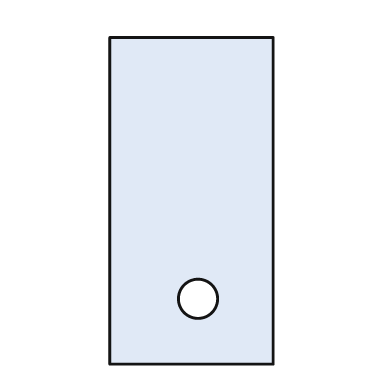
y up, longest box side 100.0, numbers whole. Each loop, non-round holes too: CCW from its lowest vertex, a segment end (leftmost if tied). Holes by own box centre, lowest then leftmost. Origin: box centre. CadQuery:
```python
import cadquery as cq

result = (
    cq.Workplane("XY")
    .moveTo(-25.0, -50.0)
    .lineTo(25.0, -50.0)
    .lineTo(25.0, 50.0)
    .lineTo(-25.0, 50.0)
    .close()
    .moveTo(2.0, -30.0)
    .circle(6.0)
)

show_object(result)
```